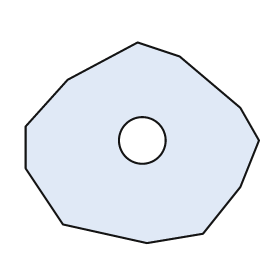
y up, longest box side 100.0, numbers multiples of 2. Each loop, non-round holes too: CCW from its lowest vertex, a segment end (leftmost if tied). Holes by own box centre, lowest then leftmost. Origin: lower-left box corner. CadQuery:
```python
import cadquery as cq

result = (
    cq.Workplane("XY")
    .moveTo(52.0, 0.0)
    .lineTo(76.0, 4.0)
    .lineTo(92.0, 24.0)
    .lineTo(100.0, 44.0)
    .lineTo(92.0, 58.0)
    .lineTo(66.0, 80.0)
    .lineTo(48.0, 86.0)
    .lineTo(18.0, 70.0)
    .lineTo(0.0, 50.0)
    .lineTo(0.0, 32.0)
    .lineTo(16.0, 8.0)
    .close()
    .moveTo(50.0, 44.0)
    .circle(10.0)
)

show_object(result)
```